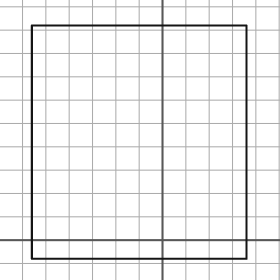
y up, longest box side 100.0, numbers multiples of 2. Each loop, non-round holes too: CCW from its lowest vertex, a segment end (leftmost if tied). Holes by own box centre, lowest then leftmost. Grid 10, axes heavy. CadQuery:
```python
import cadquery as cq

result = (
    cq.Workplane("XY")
    .moveTo(-56.0, -8.0)
    .lineTo(36.0, -8.0)
    .lineTo(36.0, 92.0)
    .lineTo(-56.0, 92.0)
    .close()
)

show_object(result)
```